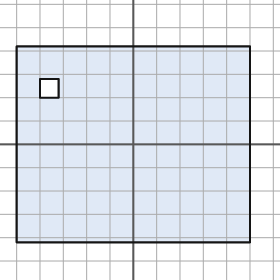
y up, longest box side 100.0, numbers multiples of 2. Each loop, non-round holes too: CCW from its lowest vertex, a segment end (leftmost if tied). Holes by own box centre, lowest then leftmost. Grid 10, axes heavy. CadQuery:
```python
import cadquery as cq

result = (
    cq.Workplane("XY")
    .moveTo(-50.0, -42.0)
    .lineTo(50.0, -42.0)
    .lineTo(50.0, 42.0)
    .lineTo(-50.0, 42.0)
    .close()
    .moveTo(-40.0, 20.0)
    .lineTo(-32.0, 20.0)
    .lineTo(-32.0, 28.0)
    .lineTo(-40.0, 28.0)
    .close()
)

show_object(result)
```